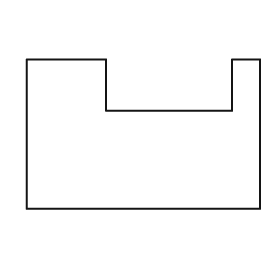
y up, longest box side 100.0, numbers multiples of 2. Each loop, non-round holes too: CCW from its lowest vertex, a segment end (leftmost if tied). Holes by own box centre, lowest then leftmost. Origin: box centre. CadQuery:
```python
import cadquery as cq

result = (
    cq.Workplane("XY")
    .moveTo(-50.0, -32.0)
    .lineTo(50.0, -32.0)
    .lineTo(50.0, 32.0)
    .lineTo(38.0, 32.0)
    .lineTo(38.0, 10.0)
    .lineTo(-16.0, 10.0)
    .lineTo(-16.0, 32.0)
    .lineTo(-50.0, 32.0)
    .close()
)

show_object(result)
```